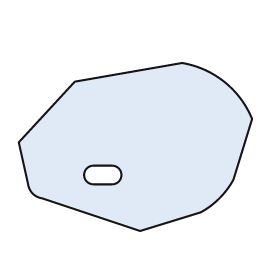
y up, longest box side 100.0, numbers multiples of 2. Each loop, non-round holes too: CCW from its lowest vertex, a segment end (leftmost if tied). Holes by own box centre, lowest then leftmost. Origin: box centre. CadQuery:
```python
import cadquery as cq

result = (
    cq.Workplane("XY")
    .moveTo(2.0, -36.0)
    .lineTo(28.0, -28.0)
    .threePointArc((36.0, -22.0), (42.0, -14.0))
    .lineTo(50.0, 12.0)
    .threePointArc((38.0, 28.0), (20.0, 36.0))
    .lineTo(-26.0, 28.0)
    .lineTo(-50.0, 2.0)
    .lineTo(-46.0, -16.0)
    .threePointArc((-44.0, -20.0), (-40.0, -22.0))
    .close()
    .moveTo(-18.0, -16.0)
    .lineTo(-10.0, -16.0)
    .threePointArc((-6.0, -12.0), (-10.0, -8.0))
    .lineTo(-18.0, -8.0)
    .threePointArc((-22.0, -12.0), (-18.0, -16.0))
    .close()
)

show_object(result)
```